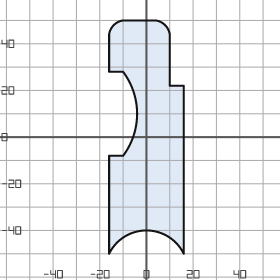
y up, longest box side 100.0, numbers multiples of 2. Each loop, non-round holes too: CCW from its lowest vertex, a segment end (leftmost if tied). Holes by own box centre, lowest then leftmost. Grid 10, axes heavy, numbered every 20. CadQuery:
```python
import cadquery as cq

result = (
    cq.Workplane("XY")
    .moveTo(-16.0, -50.0)
    .threePointArc((0.0, -40.0), (16.0, -50.0))
    .lineTo(16.0, 22.0)
    .lineTo(10.0, 22.0)
    .lineTo(10.0, 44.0)
    .threePointArc((8.0, 48.0), (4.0, 50.0))
    .lineTo(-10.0, 50.0)
    .threePointArc((-14.0, 48.0), (-16.0, 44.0))
    .lineTo(-16.0, 28.0)
    .lineTo(-10.0, 28.0)
    .threePointArc((-4.0, 10.0), (-10.0, -8.0))
    .lineTo(-16.0, -8.0)
    .close()
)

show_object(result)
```